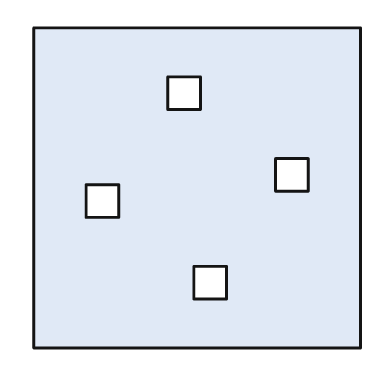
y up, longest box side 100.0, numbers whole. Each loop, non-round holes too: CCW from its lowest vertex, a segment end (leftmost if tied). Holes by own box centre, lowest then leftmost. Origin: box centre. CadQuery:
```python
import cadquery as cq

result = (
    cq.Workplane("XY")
    .moveTo(-50.0, -49.0)
    .lineTo(50.0, -49.0)
    .lineTo(50.0, 49.0)
    .lineTo(-50.0, 49.0)
    .close()
    .moveTo(-1.0, -34.0)
    .lineTo(9.0, -34.0)
    .lineTo(9.0, -24.0)
    .lineTo(-1.0, -24.0)
    .close()
    .moveTo(-34.0, -9.0)
    .lineTo(-24.0, -9.0)
    .lineTo(-24.0, 1.0)
    .lineTo(-34.0, 1.0)
    .close()
    .moveTo(24.0, -1.0)
    .lineTo(34.0, -1.0)
    .lineTo(34.0, 9.0)
    .lineTo(24.0, 9.0)
    .close()
    .moveTo(-9.0, 24.0)
    .lineTo(1.0, 24.0)
    .lineTo(1.0, 34.0)
    .lineTo(-9.0, 34.0)
    .close()
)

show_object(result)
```